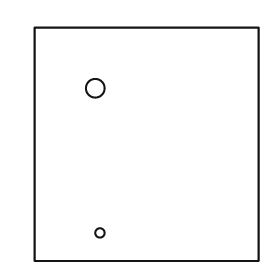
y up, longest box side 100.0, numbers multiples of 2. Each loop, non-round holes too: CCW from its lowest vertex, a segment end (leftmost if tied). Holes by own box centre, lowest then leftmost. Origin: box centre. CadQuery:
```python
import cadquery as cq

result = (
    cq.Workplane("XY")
    .moveTo(-48.0, -50.0)
    .lineTo(48.0, -50.0)
    .lineTo(48.0, 50.0)
    .lineTo(-48.0, 50.0)
    .close()
    .moveTo(-20.0, -38.0)
    .circle(2.0)
    .moveTo(-22.0, 24.0)
    .circle(4.0)
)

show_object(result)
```